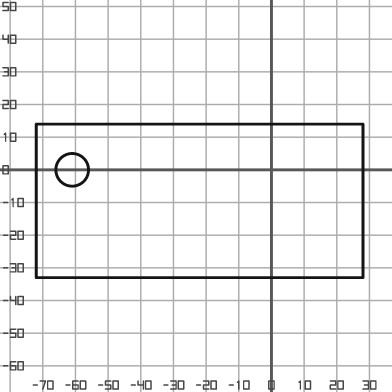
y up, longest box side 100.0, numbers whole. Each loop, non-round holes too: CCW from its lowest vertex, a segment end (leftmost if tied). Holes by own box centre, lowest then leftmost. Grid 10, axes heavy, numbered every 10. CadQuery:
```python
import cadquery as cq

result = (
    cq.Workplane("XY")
    .moveTo(-72.0, -33.0)
    .lineTo(28.0, -33.0)
    .lineTo(28.0, 14.0)
    .lineTo(-72.0, 14.0)
    .close()
    .moveTo(-61.0, 0.0)
    .circle(5.0)
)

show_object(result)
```